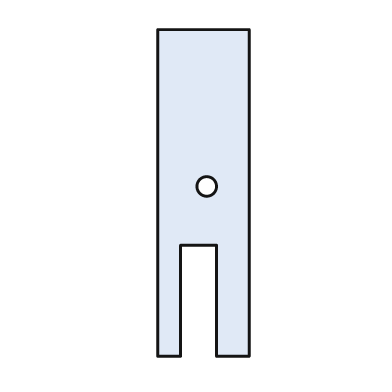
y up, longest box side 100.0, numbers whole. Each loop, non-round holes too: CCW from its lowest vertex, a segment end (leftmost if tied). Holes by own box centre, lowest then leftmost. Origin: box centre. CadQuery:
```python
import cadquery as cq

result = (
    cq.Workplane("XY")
    .moveTo(-14.0, -50.0)
    .lineTo(-7.0, -50.0)
    .lineTo(-7.0, -16.0)
    .lineTo(4.0, -16.0)
    .lineTo(4.0, -50.0)
    .lineTo(14.0, -50.0)
    .lineTo(14.0, 50.0)
    .lineTo(-14.0, 50.0)
    .close()
    .moveTo(1.0, 2.0)
    .circle(3.0)
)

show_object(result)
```